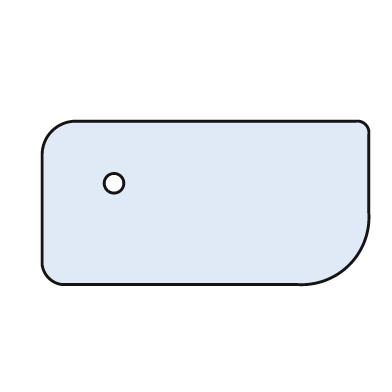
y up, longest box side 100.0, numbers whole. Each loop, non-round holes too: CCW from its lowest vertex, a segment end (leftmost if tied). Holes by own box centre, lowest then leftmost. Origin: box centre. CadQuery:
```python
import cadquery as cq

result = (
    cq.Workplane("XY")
    .moveTo(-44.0, -25.0)
    .lineTo(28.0, -25.0)
    .threePointArc((44.0, -19.0), (50.0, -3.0))
    .lineTo(50.0, 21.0)
    .threePointArc((49.0, 24.0), (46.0, 25.0))
    .lineTo(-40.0, 25.0)
    .threePointArc((-47.0, 22.0), (-50.0, 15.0))
    .lineTo(-50.0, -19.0)
    .threePointArc((-48.0, -23.0), (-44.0, -25.0))
    .close()
    .moveTo(-28.0, 6.0)
    .circle(3.0)
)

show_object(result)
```